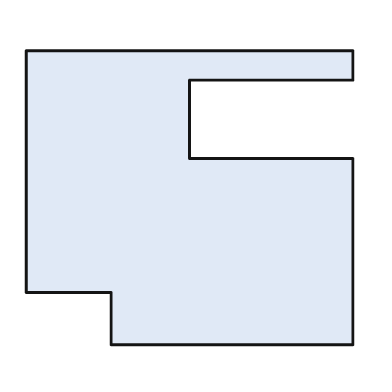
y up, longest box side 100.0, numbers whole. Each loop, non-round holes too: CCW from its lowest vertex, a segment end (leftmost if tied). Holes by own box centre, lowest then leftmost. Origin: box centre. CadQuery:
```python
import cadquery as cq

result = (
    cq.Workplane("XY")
    .moveTo(-24.0, -45.0)
    .lineTo(50.0, -45.0)
    .lineTo(50.0, 12.0)
    .lineTo(0.0, 12.0)
    .lineTo(0.0, 36.0)
    .lineTo(50.0, 36.0)
    .lineTo(50.0, 45.0)
    .lineTo(-50.0, 45.0)
    .lineTo(-50.0, -29.0)
    .lineTo(-24.0, -29.0)
    .close()
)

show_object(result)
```